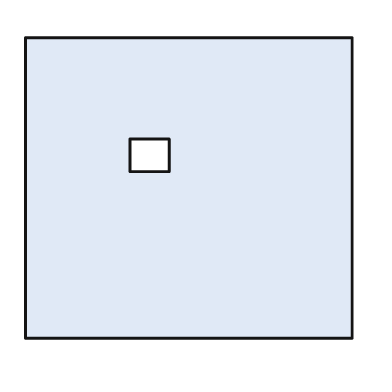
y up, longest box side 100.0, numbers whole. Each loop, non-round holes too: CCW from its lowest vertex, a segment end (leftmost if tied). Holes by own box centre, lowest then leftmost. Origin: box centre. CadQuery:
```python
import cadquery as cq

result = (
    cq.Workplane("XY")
    .moveTo(-50.0, -46.0)
    .lineTo(50.0, -46.0)
    .lineTo(50.0, 46.0)
    .lineTo(-50.0, 46.0)
    .close()
    .moveTo(-18.0, 5.0)
    .lineTo(-6.0, 5.0)
    .lineTo(-6.0, 15.0)
    .lineTo(-18.0, 15.0)
    .close()
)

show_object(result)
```